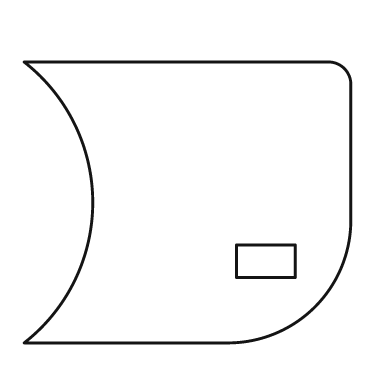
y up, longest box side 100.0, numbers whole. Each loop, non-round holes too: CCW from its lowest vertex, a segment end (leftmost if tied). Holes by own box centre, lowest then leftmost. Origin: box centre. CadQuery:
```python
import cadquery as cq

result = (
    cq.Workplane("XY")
    .moveTo(-50.0, -43.0)
    .lineTo(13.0, -43.0)
    .threePointArc((39.0, -32.0), (50.0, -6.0))
    .lineTo(50.0, 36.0)
    .threePointArc((48.0, 41.0), (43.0, 43.0))
    .lineTo(-50.0, 43.0)
    .threePointArc((-29.0, 0.0), (-50.0, -43.0))
    .close()
    .moveTo(15.0, -23.0)
    .lineTo(33.0, -23.0)
    .lineTo(33.0, -13.0)
    .lineTo(15.0, -13.0)
    .close()
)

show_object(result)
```